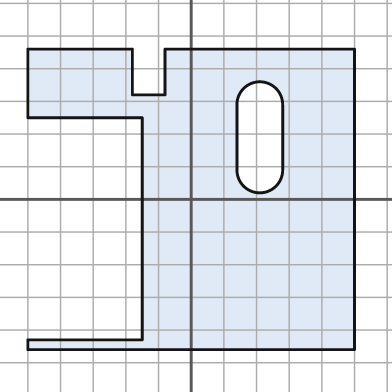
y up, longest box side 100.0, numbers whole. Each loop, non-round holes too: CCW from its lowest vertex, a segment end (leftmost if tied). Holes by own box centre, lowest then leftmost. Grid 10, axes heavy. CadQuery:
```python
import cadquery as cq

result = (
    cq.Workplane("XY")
    .moveTo(-50.0, -46.0)
    .lineTo(50.0, -46.0)
    .lineTo(50.0, 46.0)
    .lineTo(-8.0, 46.0)
    .lineTo(-8.0, 32.0)
    .lineTo(-18.0, 32.0)
    .lineTo(-18.0, 46.0)
    .lineTo(-50.0, 46.0)
    .lineTo(-50.0, 25.0)
    .lineTo(-15.0, 25.0)
    .lineTo(-15.0, -43.0)
    .lineTo(-50.0, -43.0)
    .close()
    .moveTo(14.0, 9.0)
    .threePointArc((21.0, 2.0), (28.0, 9.0))
    .lineTo(28.0, 29.0)
    .threePointArc((21.0, 36.0), (14.0, 29.0))
    .close()
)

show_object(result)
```